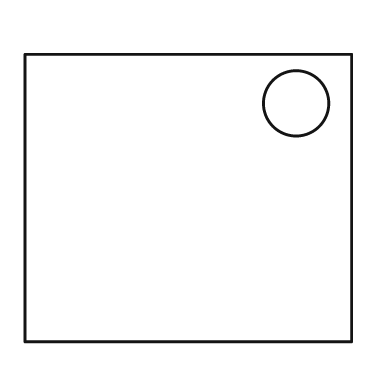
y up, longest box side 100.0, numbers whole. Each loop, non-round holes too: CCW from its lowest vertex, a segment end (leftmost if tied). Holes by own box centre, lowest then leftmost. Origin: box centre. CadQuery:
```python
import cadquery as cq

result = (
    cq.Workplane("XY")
    .moveTo(-50.0, -44.0)
    .lineTo(50.0, -44.0)
    .lineTo(50.0, 44.0)
    .lineTo(-50.0, 44.0)
    .close()
    .moveTo(33.0, 29.0)
    .circle(10.0)
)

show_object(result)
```